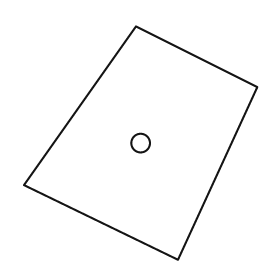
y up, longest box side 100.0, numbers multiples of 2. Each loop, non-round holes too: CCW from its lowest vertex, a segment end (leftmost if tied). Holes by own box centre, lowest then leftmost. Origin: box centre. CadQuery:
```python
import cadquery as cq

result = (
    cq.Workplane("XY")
    .moveTo(16.0, -50.0)
    .lineTo(50.0, 24.0)
    .lineTo(-2.0, 50.0)
    .lineTo(-50.0, -18.0)
    .close()
    .moveTo(0.0, 0.0)
    .circle(4.0)
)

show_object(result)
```